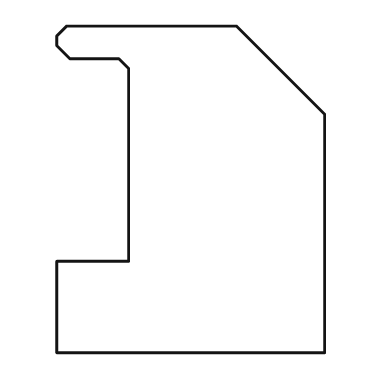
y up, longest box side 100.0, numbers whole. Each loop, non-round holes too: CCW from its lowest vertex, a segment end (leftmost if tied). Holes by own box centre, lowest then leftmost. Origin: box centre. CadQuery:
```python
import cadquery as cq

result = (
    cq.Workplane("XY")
    .moveTo(-41.0, -50.0)
    .lineTo(41.0, -50.0)
    .lineTo(41.0, 23.0)
    .lineTo(14.0, 50.0)
    .lineTo(-38.0, 50.0)
    .lineTo(-41.0, 47.0)
    .lineTo(-41.0, 44.0)
    .lineTo(-37.0, 40.0)
    .lineTo(-22.0, 40.0)
    .lineTo(-19.0, 37.0)
    .lineTo(-19.0, -22.0)
    .lineTo(-41.0, -22.0)
    .close()
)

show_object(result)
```